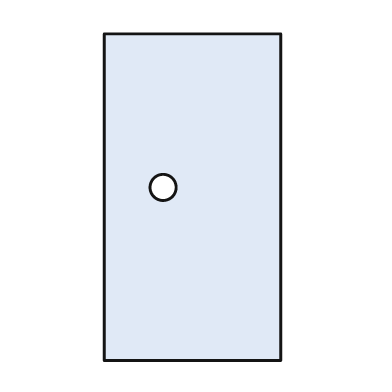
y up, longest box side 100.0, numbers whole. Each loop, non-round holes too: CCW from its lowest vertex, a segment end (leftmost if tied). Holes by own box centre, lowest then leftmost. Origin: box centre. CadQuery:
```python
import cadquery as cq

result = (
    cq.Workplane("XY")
    .moveTo(-27.0, -50.0)
    .lineTo(27.0, -50.0)
    .lineTo(27.0, 50.0)
    .lineTo(-27.0, 50.0)
    .close()
    .moveTo(-9.0, 3.0)
    .circle(4.0)
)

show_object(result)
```